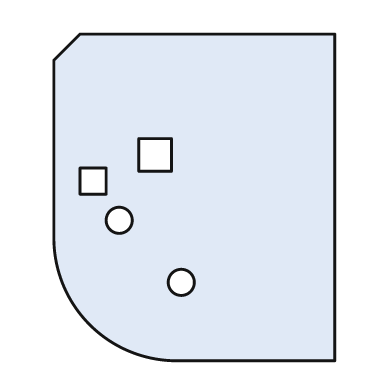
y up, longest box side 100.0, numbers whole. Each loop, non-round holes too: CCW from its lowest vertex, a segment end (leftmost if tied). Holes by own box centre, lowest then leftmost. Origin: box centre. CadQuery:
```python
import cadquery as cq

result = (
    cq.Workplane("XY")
    .moveTo(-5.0, -50.0)
    .lineTo(43.0, -50.0)
    .lineTo(43.0, 50.0)
    .lineTo(-35.0, 50.0)
    .lineTo(-43.0, 42.0)
    .lineTo(-43.0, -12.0)
    .threePointArc((-32.0, -39.0), (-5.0, -50.0))
    .close()
    .moveTo(-4.0, -26.0)
    .circle(4.0)
    .moveTo(-23.0, -7.0)
    .circle(4.0)
    .moveTo(-35.0, 1.0)
    .lineTo(-27.0, 1.0)
    .lineTo(-27.0, 9.0)
    .lineTo(-35.0, 9.0)
    .close()
    .moveTo(-17.0, 8.0)
    .lineTo(-7.0, 8.0)
    .lineTo(-7.0, 18.0)
    .lineTo(-17.0, 18.0)
    .close()
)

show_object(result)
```